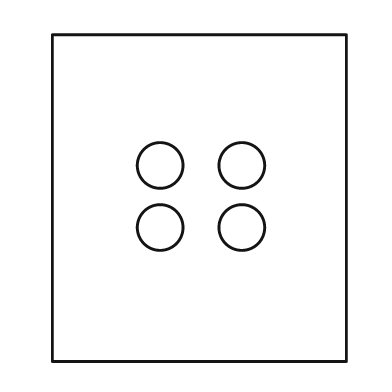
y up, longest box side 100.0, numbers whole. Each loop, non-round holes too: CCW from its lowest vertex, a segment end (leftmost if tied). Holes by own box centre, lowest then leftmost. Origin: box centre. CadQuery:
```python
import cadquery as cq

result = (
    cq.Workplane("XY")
    .moveTo(-45.0, -50.0)
    .lineTo(45.0, -50.0)
    .lineTo(45.0, 50.0)
    .lineTo(-45.0, 50.0)
    .close()
    .moveTo(-12.0, -9.0)
    .circle(7.0)
    .moveTo(13.0, -9.0)
    .circle(7.0)
    .moveTo(-12.0, 10.0)
    .circle(7.0)
    .moveTo(13.0, 10.0)
    .circle(7.0)
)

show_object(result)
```